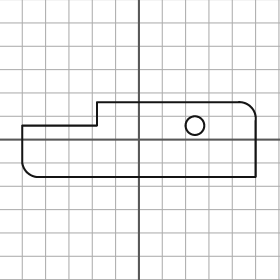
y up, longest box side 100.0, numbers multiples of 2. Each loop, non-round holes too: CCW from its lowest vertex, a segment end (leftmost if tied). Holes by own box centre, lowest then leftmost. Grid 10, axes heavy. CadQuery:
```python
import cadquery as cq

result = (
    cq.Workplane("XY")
    .moveTo(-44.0, -16.0)
    .lineTo(50.0, -16.0)
    .lineTo(50.0, 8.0)
    .threePointArc((48.0, 14.0), (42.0, 16.0))
    .lineTo(-18.0, 16.0)
    .lineTo(-18.0, 6.0)
    .lineTo(-50.0, 6.0)
    .lineTo(-50.0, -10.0)
    .threePointArc((-48.0, -14.0), (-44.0, -16.0))
    .close()
    .moveTo(24.0, 6.0)
    .circle(4.0)
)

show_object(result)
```